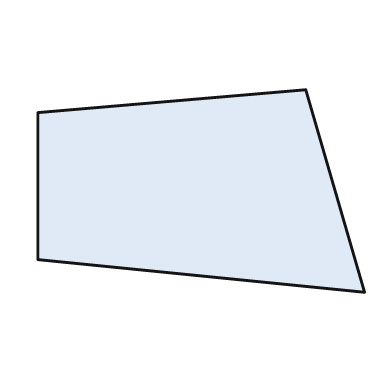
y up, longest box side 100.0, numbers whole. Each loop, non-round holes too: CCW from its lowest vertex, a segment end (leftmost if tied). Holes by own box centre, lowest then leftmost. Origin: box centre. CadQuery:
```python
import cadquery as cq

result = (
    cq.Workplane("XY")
    .moveTo(50.0, -31.0)
    .lineTo(32.0, 31.0)
    .lineTo(-50.0, 24.0)
    .lineTo(-50.0, -21.0)
    .close()
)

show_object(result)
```